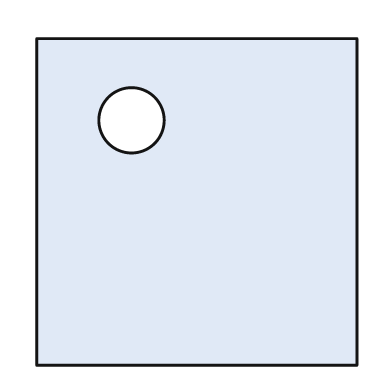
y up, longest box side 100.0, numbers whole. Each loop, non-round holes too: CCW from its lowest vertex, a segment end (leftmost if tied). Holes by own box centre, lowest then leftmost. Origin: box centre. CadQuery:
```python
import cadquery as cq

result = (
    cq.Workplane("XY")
    .moveTo(-49.0, -50.0)
    .lineTo(49.0, -50.0)
    .lineTo(49.0, 50.0)
    .lineTo(-49.0, 50.0)
    .close()
    .moveTo(-20.0, 25.0)
    .circle(10.0)
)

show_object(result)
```